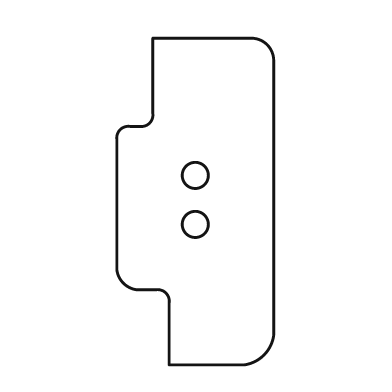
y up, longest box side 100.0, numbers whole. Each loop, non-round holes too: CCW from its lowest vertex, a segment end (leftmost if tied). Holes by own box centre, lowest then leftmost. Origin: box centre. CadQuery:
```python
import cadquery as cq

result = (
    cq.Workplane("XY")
    .moveTo(-8.0, -50.0)
    .lineTo(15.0, -50.0)
    .threePointArc((21.0, -47.0), (24.0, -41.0))
    .lineTo(24.0, 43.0)
    .threePointArc((22.0, 48.0), (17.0, 50.0))
    .lineTo(-13.0, 50.0)
    .lineTo(-13.0, 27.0)
    .threePointArc((-14.0, 24.0), (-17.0, 23.0))
    .lineTo(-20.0, 23.0)
    .threePointArc((-23.0, 22.0), (-24.0, 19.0))
    .lineTo(-24.0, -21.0)
    .threePointArc((-22.0, -25.0), (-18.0, -27.0))
    .lineTo(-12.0, -27.0)
    .threePointArc((-9.0, -28.0), (-8.0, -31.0))
    .close()
    .moveTo(0.0, -7.0)
    .circle(4.0)
    .moveTo(0.0, 8.0)
    .circle(4.0)
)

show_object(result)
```